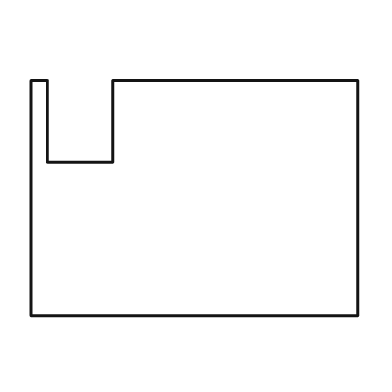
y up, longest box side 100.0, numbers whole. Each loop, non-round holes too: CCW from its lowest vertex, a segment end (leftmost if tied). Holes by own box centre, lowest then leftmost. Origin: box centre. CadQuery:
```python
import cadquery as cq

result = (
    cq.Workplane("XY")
    .moveTo(-50.0, -36.0)
    .lineTo(50.0, -36.0)
    .lineTo(50.0, 36.0)
    .lineTo(-25.0, 36.0)
    .lineTo(-25.0, 11.0)
    .lineTo(-45.0, 11.0)
    .lineTo(-45.0, 36.0)
    .lineTo(-50.0, 36.0)
    .close()
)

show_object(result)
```